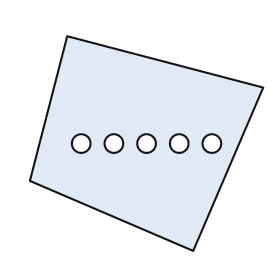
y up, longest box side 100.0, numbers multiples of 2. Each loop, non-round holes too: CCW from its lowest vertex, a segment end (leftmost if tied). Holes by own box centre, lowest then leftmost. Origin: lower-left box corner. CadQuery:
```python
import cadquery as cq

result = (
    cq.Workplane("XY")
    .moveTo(70.0, 0.0)
    .lineTo(100.0, 70.0)
    .lineTo(16.0, 92.0)
    .lineTo(0.0, 30.0)
    .close()
    .moveTo(22.0, 46.0)
    .circle(4.0)
    .moveTo(36.0, 46.0)
    .circle(4.0)
    .moveTo(50.0, 46.0)
    .circle(4.0)
    .moveTo(64.0, 46.0)
    .circle(4.0)
    .moveTo(78.0, 46.0)
    .circle(4.0)
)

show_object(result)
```